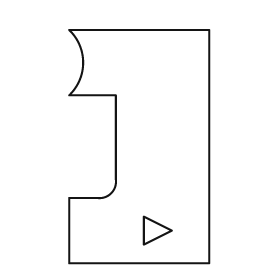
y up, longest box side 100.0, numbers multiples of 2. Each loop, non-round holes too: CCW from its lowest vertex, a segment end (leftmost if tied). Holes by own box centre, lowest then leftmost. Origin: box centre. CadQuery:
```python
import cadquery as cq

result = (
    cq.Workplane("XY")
    .moveTo(-30.0, -50.0)
    .lineTo(30.0, -50.0)
    .lineTo(30.0, 50.0)
    .lineTo(-30.0, 50.0)
    .threePointArc((-24.0, 36.0), (-30.0, 22.0))
    .lineTo(-10.0, 22.0)
    .lineTo(-10.0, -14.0)
    .threePointArc((-12.0, -20.0), (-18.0, -22.0))
    .lineTo(-30.0, -22.0)
    .close()
    .moveTo(2.0, -42.0)
    .lineTo(14.0, -36.0)
    .lineTo(2.0, -30.0)
    .close()
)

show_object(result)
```